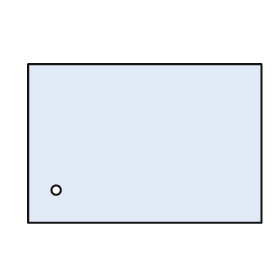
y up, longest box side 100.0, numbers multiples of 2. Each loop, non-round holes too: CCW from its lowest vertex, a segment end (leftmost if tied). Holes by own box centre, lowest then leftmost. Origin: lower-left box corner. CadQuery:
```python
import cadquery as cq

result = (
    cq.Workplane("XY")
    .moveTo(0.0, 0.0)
    .lineTo(100.0, 0.0)
    .lineTo(100.0, 68.0)
    .lineTo(0.0, 68.0)
    .close()
    .moveTo(12.0, 14.0)
    .circle(2.0)
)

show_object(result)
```